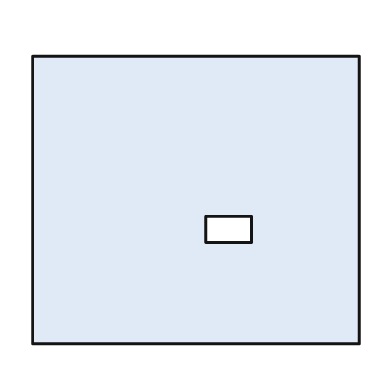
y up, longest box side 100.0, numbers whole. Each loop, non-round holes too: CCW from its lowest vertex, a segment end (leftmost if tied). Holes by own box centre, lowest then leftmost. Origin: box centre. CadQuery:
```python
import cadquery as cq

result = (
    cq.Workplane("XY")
    .moveTo(-50.0, -44.0)
    .lineTo(50.0, -44.0)
    .lineTo(50.0, 44.0)
    .lineTo(-50.0, 44.0)
    .close()
    .moveTo(3.0, -13.0)
    .lineTo(17.0, -13.0)
    .lineTo(17.0, -5.0)
    .lineTo(3.0, -5.0)
    .close()
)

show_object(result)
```